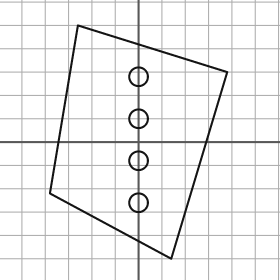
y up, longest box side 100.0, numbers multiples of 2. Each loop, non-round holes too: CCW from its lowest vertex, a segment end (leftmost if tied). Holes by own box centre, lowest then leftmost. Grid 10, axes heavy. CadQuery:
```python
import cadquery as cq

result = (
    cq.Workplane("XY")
    .moveTo(14.0, -50.0)
    .lineTo(38.0, 30.0)
    .lineTo(-26.0, 50.0)
    .lineTo(-38.0, -22.0)
    .close()
    .moveTo(0.0, -26.0)
    .circle(4.0)
    .moveTo(0.0, -8.0)
    .circle(4.0)
    .moveTo(0.0, 10.0)
    .circle(4.0)
    .moveTo(0.0, 28.0)
    .circle(4.0)
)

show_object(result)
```